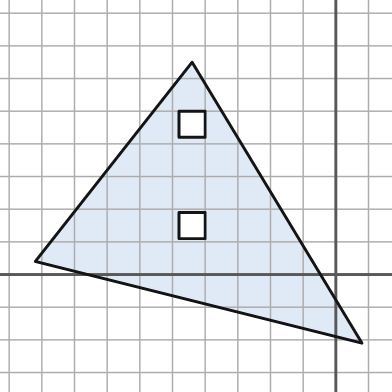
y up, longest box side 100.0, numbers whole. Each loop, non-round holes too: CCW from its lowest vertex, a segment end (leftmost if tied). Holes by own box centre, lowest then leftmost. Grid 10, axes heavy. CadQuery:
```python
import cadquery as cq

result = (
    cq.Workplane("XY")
    .moveTo(8.0, -21.0)
    .lineTo(-44.0, 65.0)
    .lineTo(-92.0, 4.0)
    .close()
    .moveTo(-48.0, 11.0)
    .lineTo(-40.0, 11.0)
    .lineTo(-40.0, 19.0)
    .lineTo(-48.0, 19.0)
    .close()
    .moveTo(-48.0, 42.0)
    .lineTo(-40.0, 42.0)
    .lineTo(-40.0, 50.0)
    .lineTo(-48.0, 50.0)
    .close()
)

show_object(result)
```